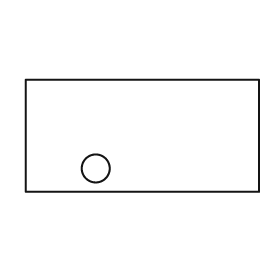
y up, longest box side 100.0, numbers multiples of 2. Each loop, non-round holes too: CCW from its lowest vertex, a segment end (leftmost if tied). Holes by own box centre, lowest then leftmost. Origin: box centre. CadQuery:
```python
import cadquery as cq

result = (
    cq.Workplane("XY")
    .moveTo(-50.0, -24.0)
    .lineTo(50.0, -24.0)
    .lineTo(50.0, 24.0)
    .lineTo(-50.0, 24.0)
    .close()
    .moveTo(-20.0, -14.0)
    .circle(6.0)
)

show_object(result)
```